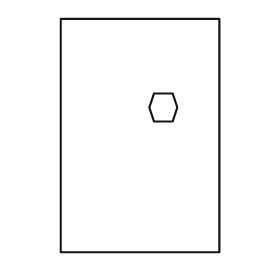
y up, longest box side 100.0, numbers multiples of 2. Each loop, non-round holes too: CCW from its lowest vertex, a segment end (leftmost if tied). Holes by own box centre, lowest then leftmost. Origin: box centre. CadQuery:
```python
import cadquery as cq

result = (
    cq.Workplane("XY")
    .moveTo(-34.0, -50.0)
    .lineTo(34.0, -50.0)
    .lineTo(34.0, 50.0)
    .lineTo(-34.0, 50.0)
    .close()
    .moveTo(6.0, 6.0)
    .lineTo(14.0, 6.0)
    .lineTo(16.0, 12.0)
    .lineTo(14.0, 18.0)
    .lineTo(6.0, 18.0)
    .lineTo(4.0, 12.0)
    .close()
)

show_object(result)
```